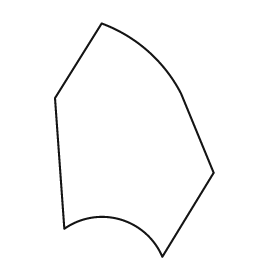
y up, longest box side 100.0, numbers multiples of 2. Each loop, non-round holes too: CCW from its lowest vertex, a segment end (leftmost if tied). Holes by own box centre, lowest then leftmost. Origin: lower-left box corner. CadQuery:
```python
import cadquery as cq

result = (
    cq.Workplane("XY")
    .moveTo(46.0, 0.0)
    .lineTo(68.0, 36.0)
    .lineTo(54.0, 70.0)
    .threePointArc((40.0, 88.0), (20.0, 100.0))
    .lineTo(0.0, 68.0)
    .lineTo(4.0, 12.0)
    .threePointArc((28.0, 16.0), (46.0, 0.0))
    .close()
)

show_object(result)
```